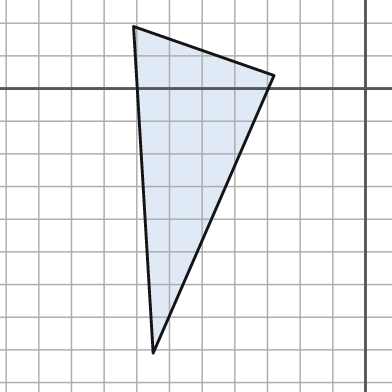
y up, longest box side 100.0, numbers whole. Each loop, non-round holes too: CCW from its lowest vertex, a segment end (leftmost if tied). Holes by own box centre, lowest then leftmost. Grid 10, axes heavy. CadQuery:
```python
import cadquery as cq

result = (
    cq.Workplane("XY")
    .moveTo(-65.0, -81.0)
    .lineTo(-28.0, 4.0)
    .lineTo(-71.0, 19.0)
    .close()
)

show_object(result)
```